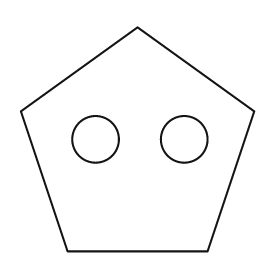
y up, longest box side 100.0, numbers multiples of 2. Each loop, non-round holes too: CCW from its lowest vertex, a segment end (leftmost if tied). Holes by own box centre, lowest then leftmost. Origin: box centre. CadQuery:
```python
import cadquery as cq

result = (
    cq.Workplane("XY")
    .moveTo(-30.0, -48.0)
    .lineTo(30.0, -48.0)
    .lineTo(50.0, 12.0)
    .lineTo(0.0, 48.0)
    .lineTo(-50.0, 12.0)
    .close()
    .moveTo(-18.0, 0.0)
    .circle(10.0)
    .moveTo(20.0, 0.0)
    .circle(10.0)
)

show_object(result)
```